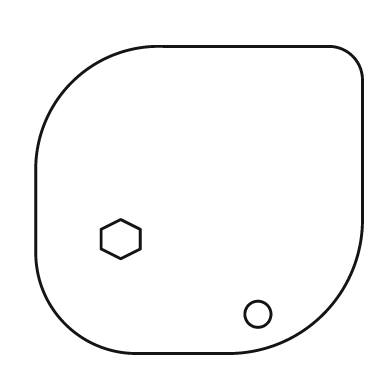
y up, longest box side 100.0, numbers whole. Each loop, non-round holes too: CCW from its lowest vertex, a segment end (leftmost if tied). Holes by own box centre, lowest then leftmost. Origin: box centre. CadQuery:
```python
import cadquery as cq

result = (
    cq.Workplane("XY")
    .moveTo(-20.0, -47.0)
    .lineTo(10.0, -47.0)
    .threePointArc((38.0, -35.0), (50.0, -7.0))
    .lineTo(50.0, 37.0)
    .threePointArc((47.0, 44.0), (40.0, 47.0))
    .lineTo(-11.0, 47.0)
    .threePointArc((-39.0, 36.0), (-50.0, 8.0))
    .lineTo(-50.0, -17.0)
    .threePointArc((-41.0, -38.0), (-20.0, -47.0))
    .close()
    .moveTo(18.0, -35.0)
    .circle(4.0)
    .moveTo(-24.0, -18.0)
    .lineTo(-18.0, -15.0)
    .lineTo(-18.0, -9.0)
    .lineTo(-24.0, -6.0)
    .lineTo(-30.0, -9.0)
    .lineTo(-30.0, -15.0)
    .close()
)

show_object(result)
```